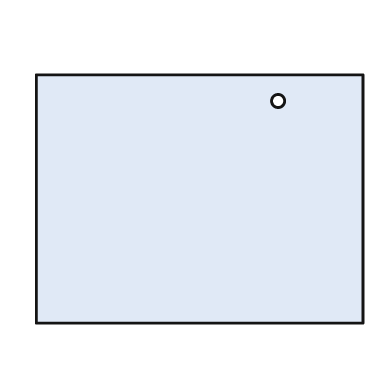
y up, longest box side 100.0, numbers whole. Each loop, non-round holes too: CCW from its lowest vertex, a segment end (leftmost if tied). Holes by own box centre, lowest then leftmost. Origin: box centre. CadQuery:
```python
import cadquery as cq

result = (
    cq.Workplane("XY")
    .moveTo(-50.0, -38.0)
    .lineTo(50.0, -38.0)
    .lineTo(50.0, 38.0)
    .lineTo(-50.0, 38.0)
    .close()
    .moveTo(24.0, 30.0)
    .circle(2.0)
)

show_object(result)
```